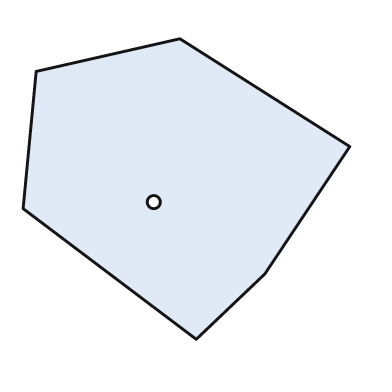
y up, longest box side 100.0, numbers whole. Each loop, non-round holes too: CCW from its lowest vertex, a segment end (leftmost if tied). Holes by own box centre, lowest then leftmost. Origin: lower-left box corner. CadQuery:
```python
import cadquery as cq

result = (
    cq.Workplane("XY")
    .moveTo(53.0, 0.0)
    .lineTo(74.0, 20.0)
    .lineTo(100.0, 59.0)
    .lineTo(48.0, 92.0)
    .lineTo(4.0, 82.0)
    .lineTo(0.0, 40.0)
    .close()
    .moveTo(40.0, 42.0)
    .circle(2.0)
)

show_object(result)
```